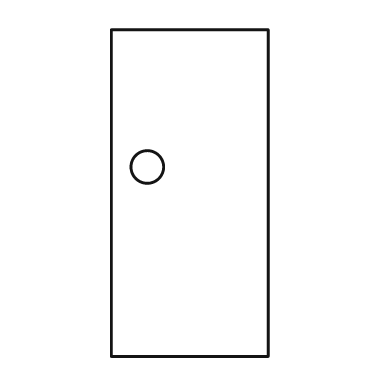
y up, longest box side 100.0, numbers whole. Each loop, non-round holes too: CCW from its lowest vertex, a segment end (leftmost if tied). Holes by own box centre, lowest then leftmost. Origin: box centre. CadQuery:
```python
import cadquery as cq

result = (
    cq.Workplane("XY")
    .moveTo(-24.0, -50.0)
    .lineTo(24.0, -50.0)
    .lineTo(24.0, 50.0)
    .lineTo(-24.0, 50.0)
    .close()
    .moveTo(-13.0, 8.0)
    .circle(5.0)
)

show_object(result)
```